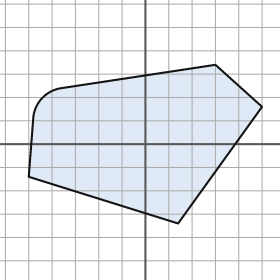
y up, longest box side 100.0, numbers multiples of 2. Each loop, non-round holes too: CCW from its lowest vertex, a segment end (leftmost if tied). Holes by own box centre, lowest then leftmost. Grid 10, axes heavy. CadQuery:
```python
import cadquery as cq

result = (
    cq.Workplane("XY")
    .moveTo(14.0, -34.0)
    .lineTo(50.0, 16.0)
    .lineTo(30.0, 34.0)
    .lineTo(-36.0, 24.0)
    .threePointArc((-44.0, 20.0), (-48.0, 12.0))
    .lineTo(-50.0, -14.0)
    .close()
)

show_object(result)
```